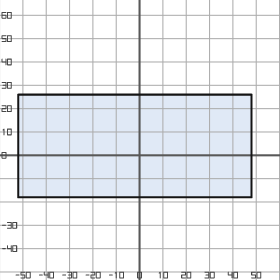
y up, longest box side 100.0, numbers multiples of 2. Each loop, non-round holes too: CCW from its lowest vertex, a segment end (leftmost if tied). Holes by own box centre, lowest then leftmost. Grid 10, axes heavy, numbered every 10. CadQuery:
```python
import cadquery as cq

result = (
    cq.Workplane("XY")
    .moveTo(-52.0, -18.0)
    .lineTo(48.0, -18.0)
    .lineTo(48.0, 26.0)
    .lineTo(-52.0, 26.0)
    .close()
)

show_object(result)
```